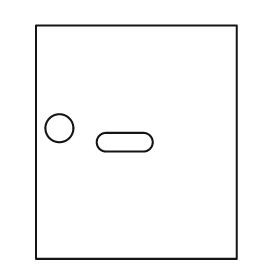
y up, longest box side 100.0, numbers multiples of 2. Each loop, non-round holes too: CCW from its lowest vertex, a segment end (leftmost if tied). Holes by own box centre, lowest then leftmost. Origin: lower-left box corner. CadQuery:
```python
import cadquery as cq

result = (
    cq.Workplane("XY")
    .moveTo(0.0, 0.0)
    .lineTo(86.0, 0.0)
    .lineTo(86.0, 100.0)
    .lineTo(0.0, 100.0)
    .close()
    .moveTo(30.0, 46.0)
    .lineTo(46.0, 46.0)
    .threePointArc((50.0, 50.0), (46.0, 54.0))
    .lineTo(30.0, 54.0)
    .threePointArc((26.0, 50.0), (30.0, 46.0))
    .close()
    .moveTo(10.0, 56.0)
    .circle(6.0)
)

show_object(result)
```